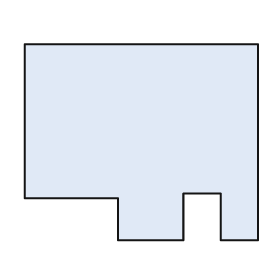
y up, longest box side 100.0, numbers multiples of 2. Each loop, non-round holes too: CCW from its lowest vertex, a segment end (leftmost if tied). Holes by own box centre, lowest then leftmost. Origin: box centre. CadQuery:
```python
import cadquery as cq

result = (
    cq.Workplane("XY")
    .moveTo(-10.0, -42.0)
    .lineTo(18.0, -42.0)
    .lineTo(18.0, -22.0)
    .lineTo(34.0, -22.0)
    .lineTo(34.0, -42.0)
    .lineTo(50.0, -42.0)
    .lineTo(50.0, 42.0)
    .lineTo(-50.0, 42.0)
    .lineTo(-50.0, -24.0)
    .lineTo(-10.0, -24.0)
    .close()
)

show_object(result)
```